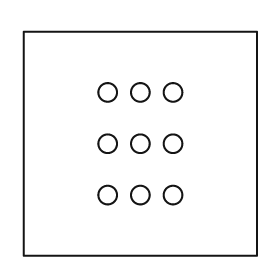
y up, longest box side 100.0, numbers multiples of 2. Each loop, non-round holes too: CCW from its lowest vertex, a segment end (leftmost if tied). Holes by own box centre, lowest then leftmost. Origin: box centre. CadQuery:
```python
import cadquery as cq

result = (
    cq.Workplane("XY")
    .moveTo(-50.0, -48.0)
    .lineTo(50.0, -48.0)
    .lineTo(50.0, 48.0)
    .lineTo(-50.0, 48.0)
    .close()
    .moveTo(-14.0, -22.0)
    .circle(4.0)
    .moveTo(0.0, -22.0)
    .circle(4.0)
    .moveTo(14.0, -22.0)
    .circle(4.0)
    .moveTo(-14.0, 0.0)
    .circle(4.0)
    .moveTo(0.0, 0.0)
    .circle(4.0)
    .moveTo(14.0, 0.0)
    .circle(4.0)
    .moveTo(-14.0, 22.0)
    .circle(4.0)
    .moveTo(0.0, 22.0)
    .circle(4.0)
    .moveTo(14.0, 22.0)
    .circle(4.0)
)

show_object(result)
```